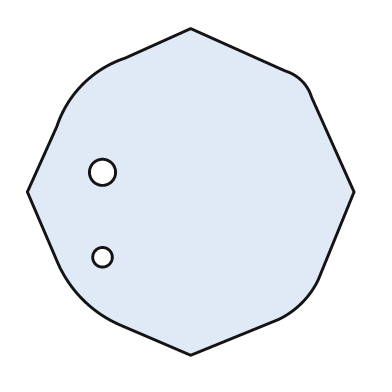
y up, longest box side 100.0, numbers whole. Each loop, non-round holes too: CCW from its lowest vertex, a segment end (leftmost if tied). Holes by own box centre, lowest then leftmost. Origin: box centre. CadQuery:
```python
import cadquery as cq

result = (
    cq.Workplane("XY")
    .moveTo(0.0, -50.0)
    .lineTo(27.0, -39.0)
    .threePointArc((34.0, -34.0), (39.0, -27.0))
    .lineTo(50.0, 0.0)
    .lineTo(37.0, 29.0)
    .threePointArc((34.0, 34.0), (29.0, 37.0))
    .lineTo(0.0, 50.0)
    .lineTo(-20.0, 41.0)
    .threePointArc((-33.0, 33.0), (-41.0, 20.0))
    .lineTo(-50.0, 0.0)
    .lineTo(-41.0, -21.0)
    .threePointArc((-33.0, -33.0), (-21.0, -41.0))
    .close()
    .moveTo(-27.0, -20.0)
    .circle(3.0)
    .moveTo(-27.0, 6.0)
    .circle(4.0)
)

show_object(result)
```